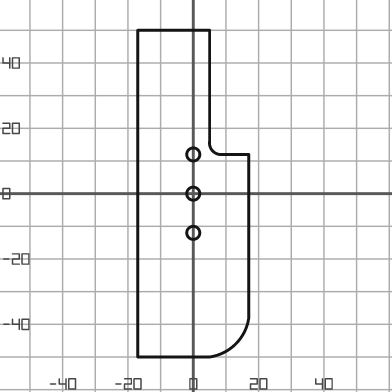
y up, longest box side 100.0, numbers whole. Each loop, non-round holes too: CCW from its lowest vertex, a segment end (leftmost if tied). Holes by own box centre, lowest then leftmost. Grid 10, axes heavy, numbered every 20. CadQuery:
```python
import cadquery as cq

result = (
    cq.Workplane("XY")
    .moveTo(-17.0, -50.0)
    .lineTo(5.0, -50.0)
    .threePointArc((13.0, -46.0), (17.0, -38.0))
    .lineTo(17.0, 12.0)
    .lineTo(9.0, 12.0)
    .threePointArc((6.0, 13.0), (5.0, 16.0))
    .lineTo(5.0, 50.0)
    .lineTo(-17.0, 50.0)
    .close()
    .moveTo(0.0, -12.0)
    .circle(2.0)
    .moveTo(0.0, 0.0)
    .circle(2.0)
    .moveTo(0.0, 12.0)
    .circle(2.0)
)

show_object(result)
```